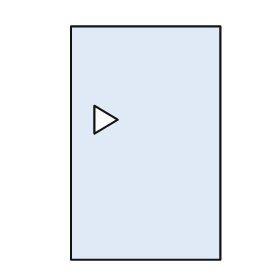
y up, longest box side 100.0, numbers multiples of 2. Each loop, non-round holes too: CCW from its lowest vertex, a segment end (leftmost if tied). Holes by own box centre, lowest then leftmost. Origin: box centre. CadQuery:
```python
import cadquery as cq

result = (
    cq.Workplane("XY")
    .moveTo(-32.0, -50.0)
    .lineTo(32.0, -50.0)
    .lineTo(32.0, 50.0)
    .lineTo(-32.0, 50.0)
    .close()
    .moveTo(-22.0, 4.0)
    .lineTo(-12.0, 10.0)
    .lineTo(-22.0, 16.0)
    .close()
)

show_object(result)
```